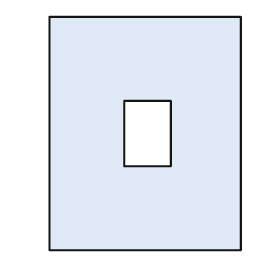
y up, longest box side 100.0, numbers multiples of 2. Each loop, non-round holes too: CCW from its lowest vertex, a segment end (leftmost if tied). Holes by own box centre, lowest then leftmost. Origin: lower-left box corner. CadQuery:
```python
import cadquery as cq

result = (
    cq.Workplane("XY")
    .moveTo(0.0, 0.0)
    .lineTo(82.0, 0.0)
    .lineTo(82.0, 100.0)
    .lineTo(0.0, 100.0)
    .close()
    .moveTo(32.0, 36.0)
    .lineTo(52.0, 36.0)
    .lineTo(52.0, 64.0)
    .lineTo(32.0, 64.0)
    .close()
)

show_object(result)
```